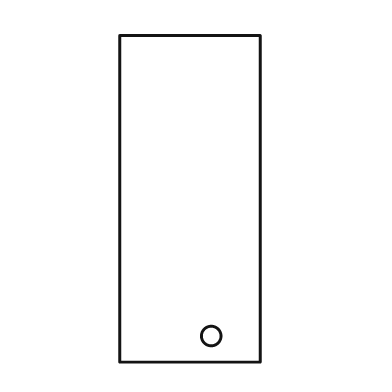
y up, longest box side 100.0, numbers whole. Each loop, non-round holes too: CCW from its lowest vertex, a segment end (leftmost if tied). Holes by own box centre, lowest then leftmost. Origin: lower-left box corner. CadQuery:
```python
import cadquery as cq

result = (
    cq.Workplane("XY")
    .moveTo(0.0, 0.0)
    .lineTo(43.0, 0.0)
    .lineTo(43.0, 100.0)
    .lineTo(0.0, 100.0)
    .close()
    .moveTo(28.0, 8.0)
    .circle(3.0)
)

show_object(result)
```